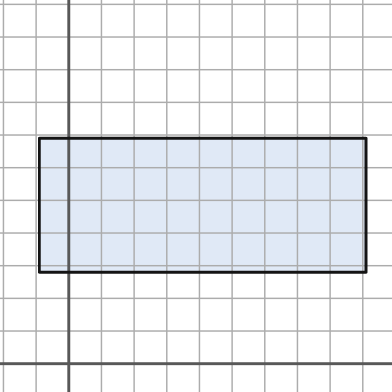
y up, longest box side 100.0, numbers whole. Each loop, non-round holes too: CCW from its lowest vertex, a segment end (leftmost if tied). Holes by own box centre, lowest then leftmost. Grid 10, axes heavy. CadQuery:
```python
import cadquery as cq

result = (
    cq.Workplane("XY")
    .moveTo(-9.0, 28.0)
    .lineTo(91.0, 28.0)
    .lineTo(91.0, 69.0)
    .lineTo(-9.0, 69.0)
    .close()
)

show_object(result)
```